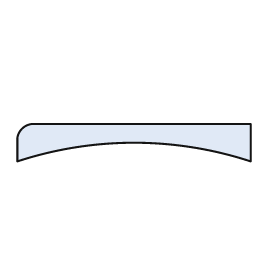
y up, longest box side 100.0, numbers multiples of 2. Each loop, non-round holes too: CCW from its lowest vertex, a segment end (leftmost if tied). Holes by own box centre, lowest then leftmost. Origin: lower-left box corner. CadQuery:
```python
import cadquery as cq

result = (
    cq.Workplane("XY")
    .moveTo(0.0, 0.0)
    .threePointArc((50.0, 8.0), (100.0, 0.0))
    .lineTo(100.0, 16.0)
    .lineTo(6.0, 16.0)
    .threePointArc((2.0, 14.0), (0.0, 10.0))
    .close()
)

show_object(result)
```